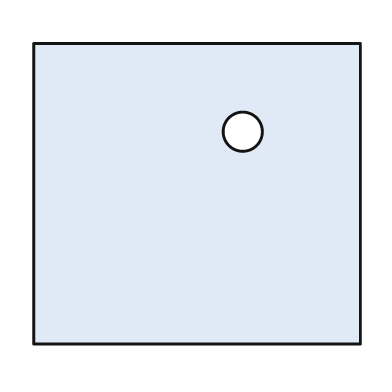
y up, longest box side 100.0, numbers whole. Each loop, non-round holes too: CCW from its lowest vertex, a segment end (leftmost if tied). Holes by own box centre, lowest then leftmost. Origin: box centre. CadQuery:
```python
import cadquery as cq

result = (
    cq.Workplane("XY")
    .moveTo(-50.0, -46.0)
    .lineTo(50.0, -46.0)
    .lineTo(50.0, 46.0)
    .lineTo(-50.0, 46.0)
    .close()
    .moveTo(14.0, 19.0)
    .circle(6.0)
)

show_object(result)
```